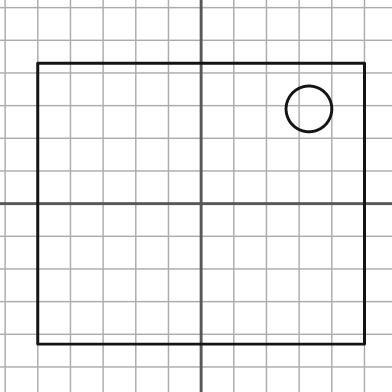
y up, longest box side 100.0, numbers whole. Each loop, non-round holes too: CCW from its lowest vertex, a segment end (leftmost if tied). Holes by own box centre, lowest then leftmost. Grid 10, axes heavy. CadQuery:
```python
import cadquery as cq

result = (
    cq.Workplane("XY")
    .moveTo(-50.0, -43.0)
    .lineTo(50.0, -43.0)
    .lineTo(50.0, 43.0)
    .lineTo(-50.0, 43.0)
    .close()
    .moveTo(33.0, 29.0)
    .circle(7.0)
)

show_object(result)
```